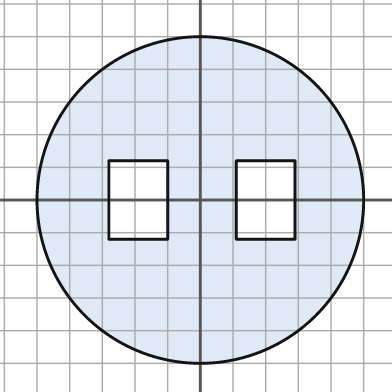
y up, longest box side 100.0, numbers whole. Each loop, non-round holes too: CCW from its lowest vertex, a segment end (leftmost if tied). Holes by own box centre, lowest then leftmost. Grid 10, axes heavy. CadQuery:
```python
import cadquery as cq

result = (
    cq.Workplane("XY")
    .moveTo(0.0, 0.0)
    .circle(50.0)
    .moveTo(-28.0, -12.0)
    .lineTo(-10.0, -12.0)
    .lineTo(-10.0, 12.0)
    .lineTo(-28.0, 12.0)
    .close()
    .moveTo(11.0, -12.0)
    .lineTo(29.0, -12.0)
    .lineTo(29.0, 12.0)
    .lineTo(11.0, 12.0)
    .close()
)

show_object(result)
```